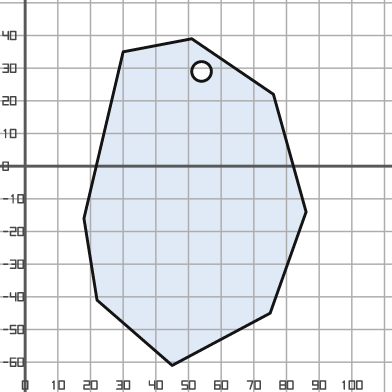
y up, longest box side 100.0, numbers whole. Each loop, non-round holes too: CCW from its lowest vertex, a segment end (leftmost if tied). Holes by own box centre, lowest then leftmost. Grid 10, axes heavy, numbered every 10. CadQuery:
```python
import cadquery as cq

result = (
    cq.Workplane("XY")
    .moveTo(45.0, -61.0)
    .lineTo(75.0, -45.0)
    .lineTo(86.0, -14.0)
    .lineTo(76.0, 22.0)
    .lineTo(51.0, 39.0)
    .lineTo(30.0, 35.0)
    .lineTo(18.0, -16.0)
    .lineTo(22.0, -41.0)
    .close()
    .moveTo(54.0, 29.0)
    .circle(3.0)
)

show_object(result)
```